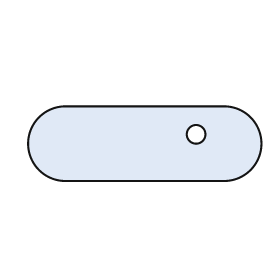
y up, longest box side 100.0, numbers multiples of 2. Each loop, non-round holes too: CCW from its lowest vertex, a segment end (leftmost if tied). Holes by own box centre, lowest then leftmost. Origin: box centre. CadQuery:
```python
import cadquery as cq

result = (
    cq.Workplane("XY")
    .moveTo(-34.0, -16.0)
    .lineTo(34.0, -16.0)
    .threePointArc((50.0, 0.0), (34.0, 16.0))
    .lineTo(-34.0, 16.0)
    .threePointArc((-50.0, 0.0), (-34.0, -16.0))
    .close()
    .moveTo(22.0, 4.0)
    .circle(4.0)
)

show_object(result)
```